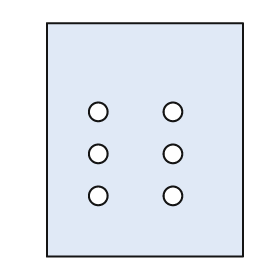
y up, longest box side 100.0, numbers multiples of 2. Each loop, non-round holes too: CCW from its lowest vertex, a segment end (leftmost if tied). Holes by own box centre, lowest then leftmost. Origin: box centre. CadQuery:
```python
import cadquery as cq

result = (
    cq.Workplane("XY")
    .moveTo(-42.0, -50.0)
    .lineTo(42.0, -50.0)
    .lineTo(42.0, 50.0)
    .lineTo(-42.0, 50.0)
    .close()
    .moveTo(-20.0, -24.0)
    .circle(4.0)
    .moveTo(12.0, -24.0)
    .circle(4.0)
    .moveTo(-20.0, -6.0)
    .circle(4.0)
    .moveTo(12.0, -6.0)
    .circle(4.0)
    .moveTo(-20.0, 12.0)
    .circle(4.0)
    .moveTo(12.0, 12.0)
    .circle(4.0)
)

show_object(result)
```